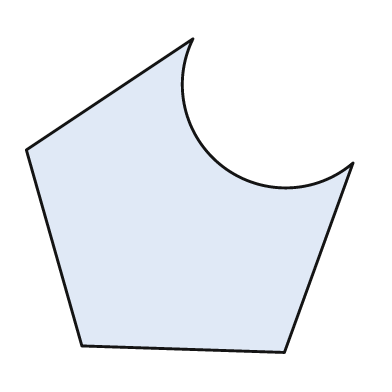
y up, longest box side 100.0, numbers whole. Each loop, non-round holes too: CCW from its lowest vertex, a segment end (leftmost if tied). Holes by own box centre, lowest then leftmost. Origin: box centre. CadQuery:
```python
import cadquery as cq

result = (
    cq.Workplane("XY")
    .moveTo(29.0, -48.0)
    .lineTo(50.0, 10.0)
    .threePointArc((10.0, 9.0), (1.0, 48.0))
    .lineTo(-50.0, 14.0)
    .lineTo(-33.0, -46.0)
    .close()
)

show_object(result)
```